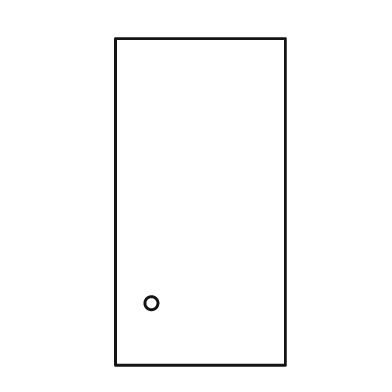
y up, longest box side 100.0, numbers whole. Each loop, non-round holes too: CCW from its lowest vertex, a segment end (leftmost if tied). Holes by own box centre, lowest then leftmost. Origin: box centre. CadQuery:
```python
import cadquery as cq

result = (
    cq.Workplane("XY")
    .moveTo(-26.0, -50.0)
    .lineTo(26.0, -50.0)
    .lineTo(26.0, 50.0)
    .lineTo(-26.0, 50.0)
    .close()
    .moveTo(-15.0, -31.0)
    .circle(2.0)
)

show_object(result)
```